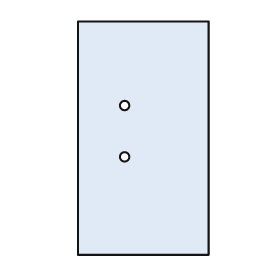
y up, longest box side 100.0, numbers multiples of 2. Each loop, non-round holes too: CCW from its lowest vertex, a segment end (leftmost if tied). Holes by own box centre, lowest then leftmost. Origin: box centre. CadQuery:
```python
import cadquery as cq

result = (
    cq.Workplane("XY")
    .moveTo(-28.0, -50.0)
    .lineTo(28.0, -50.0)
    .lineTo(28.0, 50.0)
    .lineTo(-28.0, 50.0)
    .close()
    .moveTo(-8.0, -8.0)
    .circle(2.0)
    .moveTo(-8.0, 14.0)
    .circle(2.0)
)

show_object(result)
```